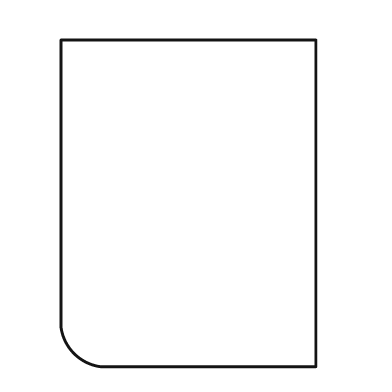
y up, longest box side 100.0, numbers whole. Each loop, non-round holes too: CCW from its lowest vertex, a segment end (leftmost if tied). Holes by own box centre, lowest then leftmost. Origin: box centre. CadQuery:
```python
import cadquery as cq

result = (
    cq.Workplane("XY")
    .moveTo(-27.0, -50.0)
    .lineTo(39.0, -50.0)
    .lineTo(39.0, 50.0)
    .lineTo(-39.0, 50.0)
    .lineTo(-39.0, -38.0)
    .threePointArc((-35.0, -46.0), (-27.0, -50.0))
    .close()
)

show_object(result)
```